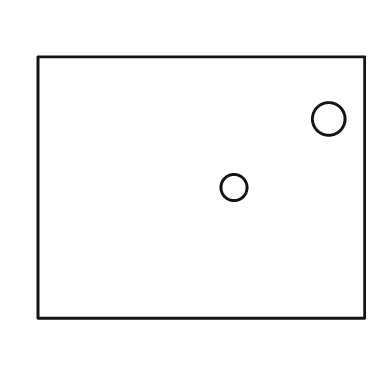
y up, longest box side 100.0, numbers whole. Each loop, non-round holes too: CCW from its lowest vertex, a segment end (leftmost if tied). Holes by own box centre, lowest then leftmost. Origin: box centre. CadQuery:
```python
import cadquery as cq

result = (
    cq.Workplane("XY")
    .moveTo(-50.0, -40.0)
    .lineTo(50.0, -40.0)
    .lineTo(50.0, 40.0)
    .lineTo(-50.0, 40.0)
    .close()
    .moveTo(10.0, 0.0)
    .circle(4.0)
    .moveTo(39.0, 21.0)
    .circle(5.0)
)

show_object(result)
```